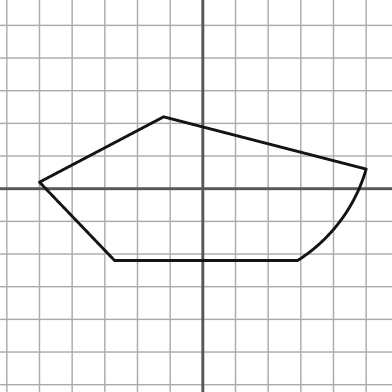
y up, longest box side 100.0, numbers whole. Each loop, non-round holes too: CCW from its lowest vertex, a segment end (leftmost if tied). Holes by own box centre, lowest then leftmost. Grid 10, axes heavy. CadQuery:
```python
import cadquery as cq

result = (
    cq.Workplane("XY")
    .moveTo(-27.0, -22.0)
    .lineTo(29.0, -22.0)
    .threePointArc((42.0, -10.0), (50.0, 6.0))
    .lineTo(-12.0, 22.0)
    .lineTo(-50.0, 2.0)
    .close()
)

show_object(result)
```